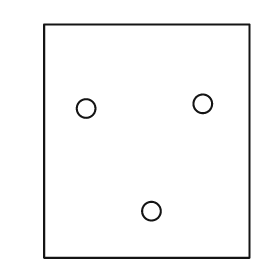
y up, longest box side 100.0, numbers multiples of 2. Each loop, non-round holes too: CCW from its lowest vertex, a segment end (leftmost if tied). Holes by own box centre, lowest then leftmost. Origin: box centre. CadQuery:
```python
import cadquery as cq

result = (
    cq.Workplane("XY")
    .moveTo(-44.0, -50.0)
    .lineTo(44.0, -50.0)
    .lineTo(44.0, 50.0)
    .lineTo(-44.0, 50.0)
    .close()
    .moveTo(2.0, -30.0)
    .circle(4.0)
    .moveTo(-26.0, 14.0)
    .circle(4.0)
    .moveTo(24.0, 16.0)
    .circle(4.0)
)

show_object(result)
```